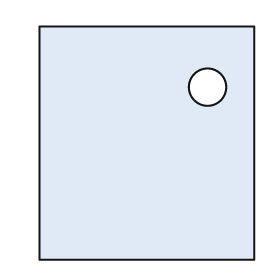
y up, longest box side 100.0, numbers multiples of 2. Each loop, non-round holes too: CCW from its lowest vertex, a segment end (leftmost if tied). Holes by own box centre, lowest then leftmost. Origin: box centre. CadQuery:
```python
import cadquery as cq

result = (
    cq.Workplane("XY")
    .moveTo(-46.0, -50.0)
    .lineTo(46.0, -50.0)
    .lineTo(46.0, 50.0)
    .lineTo(-46.0, 50.0)
    .close()
    .moveTo(26.0, 24.0)
    .circle(8.0)
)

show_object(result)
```